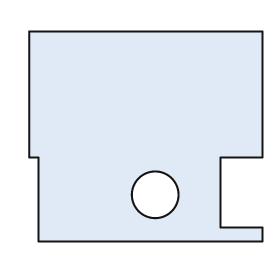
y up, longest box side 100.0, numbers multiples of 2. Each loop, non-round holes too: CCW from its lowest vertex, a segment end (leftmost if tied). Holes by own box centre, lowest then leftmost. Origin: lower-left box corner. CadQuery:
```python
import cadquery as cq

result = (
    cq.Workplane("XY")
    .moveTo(4.0, 0.0)
    .lineTo(100.0, 0.0)
    .lineTo(100.0, 6.0)
    .lineTo(82.0, 6.0)
    .lineTo(82.0, 36.0)
    .lineTo(100.0, 36.0)
    .lineTo(100.0, 90.0)
    .lineTo(0.0, 90.0)
    .lineTo(0.0, 36.0)
    .lineTo(4.0, 36.0)
    .close()
    .moveTo(54.0, 20.0)
    .circle(10.0)
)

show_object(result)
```